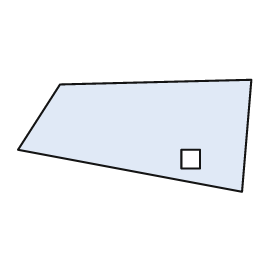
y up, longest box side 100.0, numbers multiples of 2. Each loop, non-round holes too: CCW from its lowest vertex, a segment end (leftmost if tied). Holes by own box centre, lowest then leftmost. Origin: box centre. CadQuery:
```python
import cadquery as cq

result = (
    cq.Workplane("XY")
    .moveTo(46.0, -24.0)
    .lineTo(50.0, 24.0)
    .lineTo(-32.0, 22.0)
    .lineTo(-50.0, -6.0)
    .close()
    .moveTo(20.0, -14.0)
    .lineTo(28.0, -14.0)
    .lineTo(28.0, -6.0)
    .lineTo(20.0, -6.0)
    .close()
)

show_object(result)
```